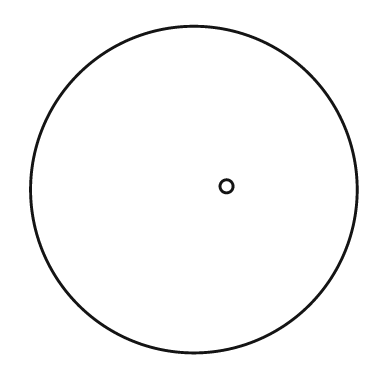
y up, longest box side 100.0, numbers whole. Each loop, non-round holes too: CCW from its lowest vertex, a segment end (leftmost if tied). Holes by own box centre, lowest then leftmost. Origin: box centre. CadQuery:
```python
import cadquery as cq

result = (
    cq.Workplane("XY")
    .moveTo(0.0, 0.0)
    .circle(50.0)
    .moveTo(10.0, 1.0)
    .circle(2.0)
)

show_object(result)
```